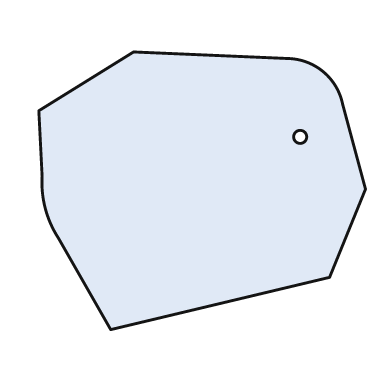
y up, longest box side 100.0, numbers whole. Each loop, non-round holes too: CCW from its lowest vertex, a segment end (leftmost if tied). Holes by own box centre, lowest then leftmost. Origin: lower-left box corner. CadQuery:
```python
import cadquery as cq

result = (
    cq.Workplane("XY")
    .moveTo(22.0, 0.0)
    .lineTo(89.0, 16.0)
    .lineTo(100.0, 43.0)
    .lineTo(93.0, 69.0)
    .threePointArc((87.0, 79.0), (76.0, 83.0))
    .lineTo(29.0, 85.0)
    .lineTo(0.0, 67.0)
    .lineTo(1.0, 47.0)
    .threePointArc((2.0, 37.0), (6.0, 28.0))
    .close()
    .moveTo(80.0, 59.0)
    .circle(2.0)
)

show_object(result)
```